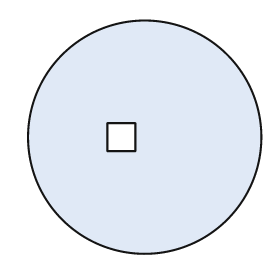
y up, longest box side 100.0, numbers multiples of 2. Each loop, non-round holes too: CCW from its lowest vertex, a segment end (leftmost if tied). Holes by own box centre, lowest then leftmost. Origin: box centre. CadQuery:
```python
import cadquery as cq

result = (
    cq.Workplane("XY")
    .moveTo(0.0, 0.0)
    .circle(50.0)
    .moveTo(-16.0, -6.0)
    .lineTo(-4.0, -6.0)
    .lineTo(-4.0, 6.0)
    .lineTo(-16.0, 6.0)
    .close()
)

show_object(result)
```